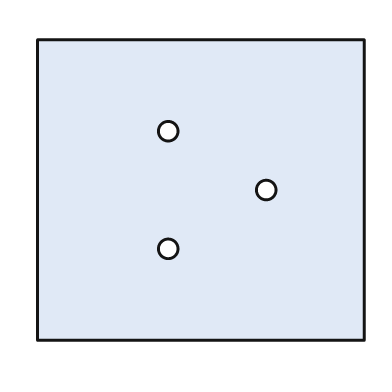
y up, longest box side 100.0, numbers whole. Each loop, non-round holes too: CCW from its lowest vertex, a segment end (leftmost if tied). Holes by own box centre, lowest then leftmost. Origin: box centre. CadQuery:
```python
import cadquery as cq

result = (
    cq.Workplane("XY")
    .moveTo(-50.0, -46.0)
    .lineTo(50.0, -46.0)
    .lineTo(50.0, 46.0)
    .lineTo(-50.0, 46.0)
    .close()
    .moveTo(-10.0, -18.0)
    .circle(3.0)
    .moveTo(20.0, 0.0)
    .circle(3.0)
    .moveTo(-10.0, 18.0)
    .circle(3.0)
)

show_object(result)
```